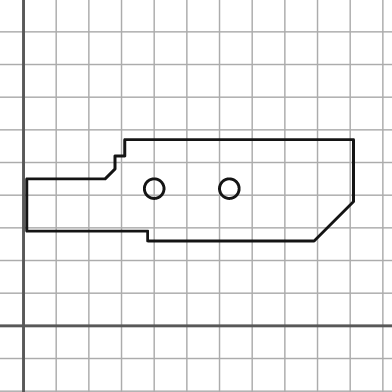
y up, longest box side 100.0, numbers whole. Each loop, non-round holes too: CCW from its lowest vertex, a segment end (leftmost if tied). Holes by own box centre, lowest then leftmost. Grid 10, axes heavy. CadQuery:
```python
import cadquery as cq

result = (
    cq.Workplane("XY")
    .moveTo(38.0, 26.0)
    .lineTo(89.0, 26.0)
    .lineTo(101.0, 38.0)
    .lineTo(101.0, 57.0)
    .lineTo(31.0, 57.0)
    .lineTo(31.0, 52.0)
    .lineTo(28.0, 52.0)
    .lineTo(28.0, 48.0)
    .lineTo(25.0, 45.0)
    .lineTo(1.0, 45.0)
    .lineTo(1.0, 29.0)
    .lineTo(38.0, 29.0)
    .close()
    .moveTo(40.0, 42.0)
    .circle(3.0)
    .moveTo(63.0, 42.0)
    .circle(3.0)
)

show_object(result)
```